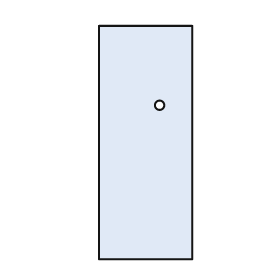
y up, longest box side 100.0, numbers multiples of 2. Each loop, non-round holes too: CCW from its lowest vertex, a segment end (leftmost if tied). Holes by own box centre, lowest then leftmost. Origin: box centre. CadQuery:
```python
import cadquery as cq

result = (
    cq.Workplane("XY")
    .moveTo(-20.0, -50.0)
    .lineTo(20.0, -50.0)
    .lineTo(20.0, 50.0)
    .lineTo(-20.0, 50.0)
    .close()
    .moveTo(6.0, 16.0)
    .circle(2.0)
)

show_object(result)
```